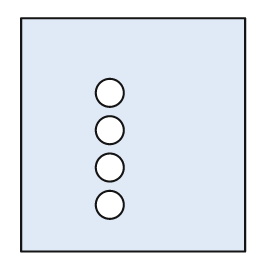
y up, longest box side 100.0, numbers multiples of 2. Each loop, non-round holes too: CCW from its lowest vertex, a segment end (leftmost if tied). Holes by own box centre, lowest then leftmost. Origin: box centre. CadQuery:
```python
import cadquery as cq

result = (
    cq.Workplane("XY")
    .moveTo(-48.0, -50.0)
    .lineTo(48.0, -50.0)
    .lineTo(48.0, 50.0)
    .lineTo(-48.0, 50.0)
    .close()
    .moveTo(-10.0, -30.0)
    .circle(6.0)
    .moveTo(-10.0, -14.0)
    .circle(6.0)
    .moveTo(-10.0, 2.0)
    .circle(6.0)
    .moveTo(-10.0, 18.0)
    .circle(6.0)
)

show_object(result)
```